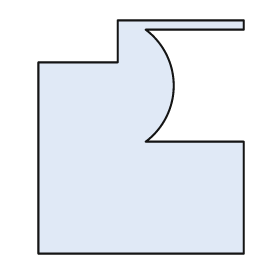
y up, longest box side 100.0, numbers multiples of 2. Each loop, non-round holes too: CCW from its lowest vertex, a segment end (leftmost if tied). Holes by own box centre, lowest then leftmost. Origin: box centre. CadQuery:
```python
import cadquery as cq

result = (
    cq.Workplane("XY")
    .moveTo(-44.0, -50.0)
    .lineTo(44.0, -50.0)
    .lineTo(44.0, -2.0)
    .lineTo(2.0, -2.0)
    .threePointArc((14.0, 22.0), (2.0, 46.0))
    .lineTo(44.0, 46.0)
    .lineTo(44.0, 50.0)
    .lineTo(-10.0, 50.0)
    .lineTo(-10.0, 32.0)
    .lineTo(-44.0, 32.0)
    .close()
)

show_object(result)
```